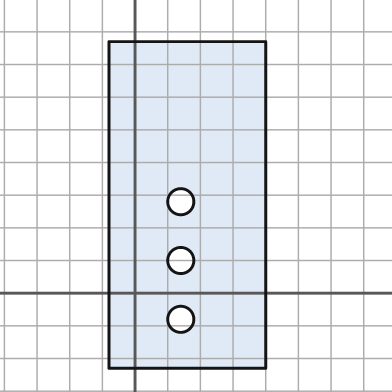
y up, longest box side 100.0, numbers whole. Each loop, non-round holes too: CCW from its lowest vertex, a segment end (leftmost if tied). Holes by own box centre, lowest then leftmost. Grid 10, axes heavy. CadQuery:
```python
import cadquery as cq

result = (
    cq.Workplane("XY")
    .moveTo(-8.0, -23.0)
    .lineTo(40.0, -23.0)
    .lineTo(40.0, 77.0)
    .lineTo(-8.0, 77.0)
    .close()
    .moveTo(14.0, -8.0)
    .circle(4.0)
    .moveTo(14.0, 10.0)
    .circle(4.0)
    .moveTo(14.0, 28.0)
    .circle(4.0)
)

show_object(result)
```